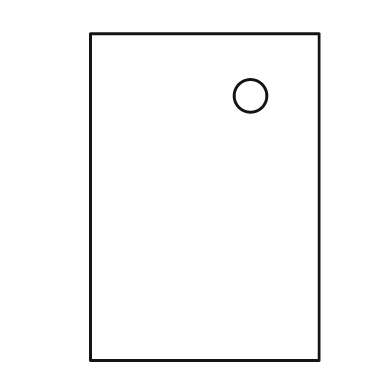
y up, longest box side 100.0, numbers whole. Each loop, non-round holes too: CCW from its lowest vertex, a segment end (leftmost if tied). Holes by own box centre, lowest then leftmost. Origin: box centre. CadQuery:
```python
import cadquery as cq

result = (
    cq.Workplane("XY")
    .moveTo(-35.0, -50.0)
    .lineTo(35.0, -50.0)
    .lineTo(35.0, 50.0)
    .lineTo(-35.0, 50.0)
    .close()
    .moveTo(14.0, 31.0)
    .circle(5.0)
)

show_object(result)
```